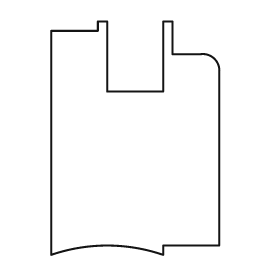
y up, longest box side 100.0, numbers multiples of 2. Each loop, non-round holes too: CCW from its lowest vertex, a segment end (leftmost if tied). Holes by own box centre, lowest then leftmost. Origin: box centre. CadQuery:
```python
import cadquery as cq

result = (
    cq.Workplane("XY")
    .moveTo(-36.0, -50.0)
    .threePointArc((-12.0, -46.0), (12.0, -50.0))
    .lineTo(12.0, -46.0)
    .lineTo(36.0, -46.0)
    .lineTo(36.0, 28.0)
    .threePointArc((34.0, 34.0), (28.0, 36.0))
    .lineTo(16.0, 36.0)
    .lineTo(16.0, 50.0)
    .lineTo(12.0, 50.0)
    .lineTo(12.0, 20.0)
    .lineTo(-12.0, 20.0)
    .lineTo(-12.0, 50.0)
    .lineTo(-16.0, 50.0)
    .lineTo(-16.0, 46.0)
    .lineTo(-36.0, 46.0)
    .close()
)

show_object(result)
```